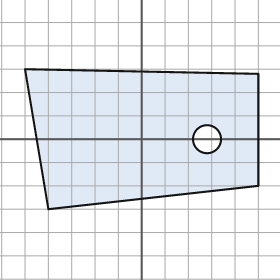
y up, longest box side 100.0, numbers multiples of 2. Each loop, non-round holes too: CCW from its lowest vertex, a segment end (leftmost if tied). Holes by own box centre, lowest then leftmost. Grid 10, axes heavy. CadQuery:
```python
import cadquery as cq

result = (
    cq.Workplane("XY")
    .moveTo(-40.0, -30.0)
    .lineTo(50.0, -20.0)
    .lineTo(50.0, 28.0)
    .lineTo(-50.0, 30.0)
    .close()
    .moveTo(28.0, 0.0)
    .circle(6.0)
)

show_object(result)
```